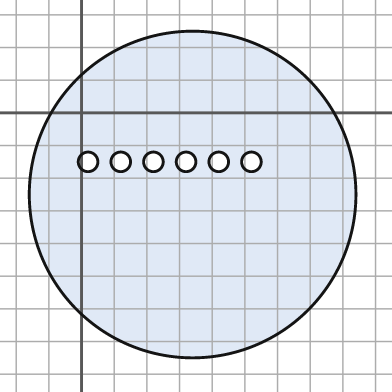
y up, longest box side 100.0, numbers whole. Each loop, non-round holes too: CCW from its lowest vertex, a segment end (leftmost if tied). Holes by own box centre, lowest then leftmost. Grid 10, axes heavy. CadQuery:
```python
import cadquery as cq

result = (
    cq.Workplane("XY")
    .moveTo(34.0, -25.0)
    .circle(50.0)
    .moveTo(2.0, -15.0)
    .circle(3.0)
    .moveTo(12.0, -15.0)
    .circle(3.0)
    .moveTo(22.0, -15.0)
    .circle(3.0)
    .moveTo(32.0, -15.0)
    .circle(3.0)
    .moveTo(42.0, -15.0)
    .circle(3.0)
    .moveTo(52.0, -15.0)
    .circle(3.0)
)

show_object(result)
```